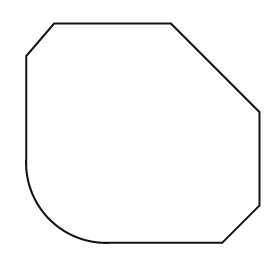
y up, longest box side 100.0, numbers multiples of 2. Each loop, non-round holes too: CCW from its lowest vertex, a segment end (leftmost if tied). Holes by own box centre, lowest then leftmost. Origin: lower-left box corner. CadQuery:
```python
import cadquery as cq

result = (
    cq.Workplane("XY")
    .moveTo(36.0, 0.0)
    .lineTo(84.0, 0.0)
    .lineTo(100.0, 16.0)
    .lineTo(100.0, 56.0)
    .lineTo(62.0, 94.0)
    .lineTo(12.0, 94.0)
    .lineTo(0.0, 80.0)
    .lineTo(0.0, 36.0)
    .threePointArc((10.0, 10.0), (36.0, 0.0))
    .close()
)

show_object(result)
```